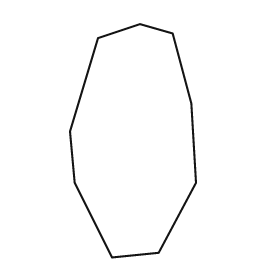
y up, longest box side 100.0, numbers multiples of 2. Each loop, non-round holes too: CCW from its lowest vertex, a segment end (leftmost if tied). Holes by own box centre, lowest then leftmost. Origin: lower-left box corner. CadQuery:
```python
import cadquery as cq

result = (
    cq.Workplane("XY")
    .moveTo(18.0, 0.0)
    .lineTo(38.0, 2.0)
    .lineTo(54.0, 32.0)
    .lineTo(52.0, 66.0)
    .lineTo(44.0, 96.0)
    .lineTo(30.0, 100.0)
    .lineTo(12.0, 94.0)
    .lineTo(0.0, 54.0)
    .lineTo(2.0, 32.0)
    .close()
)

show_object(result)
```